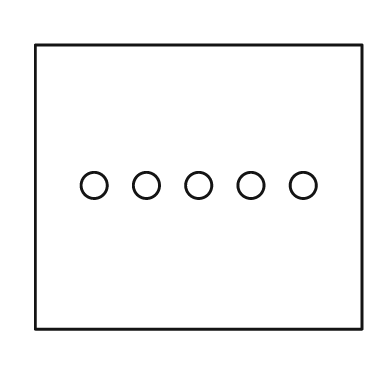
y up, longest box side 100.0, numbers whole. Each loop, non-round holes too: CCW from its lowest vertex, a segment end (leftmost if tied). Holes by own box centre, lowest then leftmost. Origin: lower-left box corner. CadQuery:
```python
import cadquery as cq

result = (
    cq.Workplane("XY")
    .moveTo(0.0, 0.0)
    .lineTo(100.0, 0.0)
    .lineTo(100.0, 87.0)
    .lineTo(0.0, 87.0)
    .close()
    .moveTo(18.0, 44.0)
    .circle(4.0)
    .moveTo(34.0, 44.0)
    .circle(4.0)
    .moveTo(50.0, 44.0)
    .circle(4.0)
    .moveTo(66.0, 44.0)
    .circle(4.0)
    .moveTo(82.0, 44.0)
    .circle(4.0)
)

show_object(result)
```